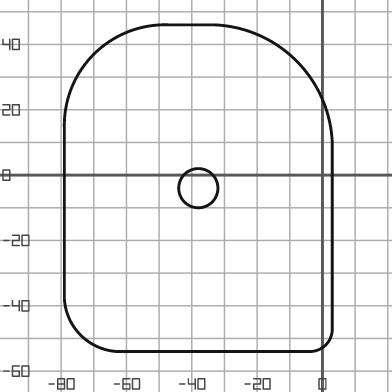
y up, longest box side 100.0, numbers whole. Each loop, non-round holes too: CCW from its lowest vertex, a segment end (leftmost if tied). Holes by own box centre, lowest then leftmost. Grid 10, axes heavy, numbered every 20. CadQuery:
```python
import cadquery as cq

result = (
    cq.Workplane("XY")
    .moveTo(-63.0, -54.0)
    .lineTo(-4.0, -54.0)
    .threePointArc((1.0, -52.0), (3.0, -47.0))
    .lineTo(3.0, 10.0)
    .threePointArc((-8.0, 35.0), (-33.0, 46.0))
    .lineTo(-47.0, 46.0)
    .threePointArc((-70.0, 37.0), (-79.0, 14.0))
    .lineTo(-79.0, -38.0)
    .threePointArc((-74.0, -49.0), (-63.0, -54.0))
    .close()
    .moveTo(-38.0, -4.0)
    .circle(6.0)
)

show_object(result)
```